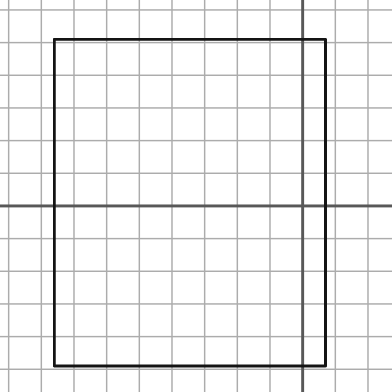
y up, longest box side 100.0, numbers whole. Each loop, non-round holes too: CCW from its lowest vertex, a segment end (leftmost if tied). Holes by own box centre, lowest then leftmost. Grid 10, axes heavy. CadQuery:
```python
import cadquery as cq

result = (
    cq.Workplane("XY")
    .moveTo(-76.0, -49.0)
    .lineTo(7.0, -49.0)
    .lineTo(7.0, 51.0)
    .lineTo(-76.0, 51.0)
    .close()
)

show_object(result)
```